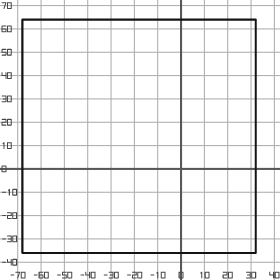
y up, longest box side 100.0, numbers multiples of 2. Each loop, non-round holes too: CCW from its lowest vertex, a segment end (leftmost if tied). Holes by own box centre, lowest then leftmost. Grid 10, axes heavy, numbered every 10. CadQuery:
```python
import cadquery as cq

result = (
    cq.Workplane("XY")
    .moveTo(-68.0, -36.0)
    .lineTo(32.0, -36.0)
    .lineTo(32.0, 64.0)
    .lineTo(-68.0, 64.0)
    .close()
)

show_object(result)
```